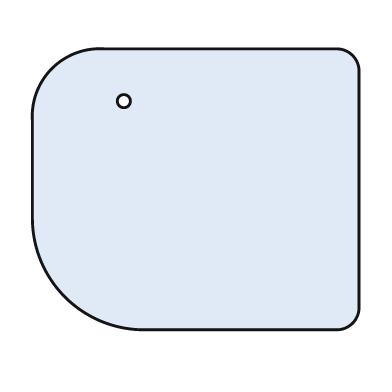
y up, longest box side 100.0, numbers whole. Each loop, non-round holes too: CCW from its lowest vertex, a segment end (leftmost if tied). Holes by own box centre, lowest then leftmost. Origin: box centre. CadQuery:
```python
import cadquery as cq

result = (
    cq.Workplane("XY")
    .moveTo(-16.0, -43.0)
    .lineTo(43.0, -43.0)
    .threePointArc((48.0, -41.0), (50.0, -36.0))
    .lineTo(50.0, 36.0)
    .threePointArc((48.0, 41.0), (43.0, 43.0))
    .lineTo(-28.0, 43.0)
    .threePointArc((-44.0, 37.0), (-50.0, 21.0))
    .lineTo(-50.0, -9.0)
    .threePointArc((-40.0, -33.0), (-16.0, -43.0))
    .close()
    .moveTo(-22.0, 27.0)
    .circle(2.0)
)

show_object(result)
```